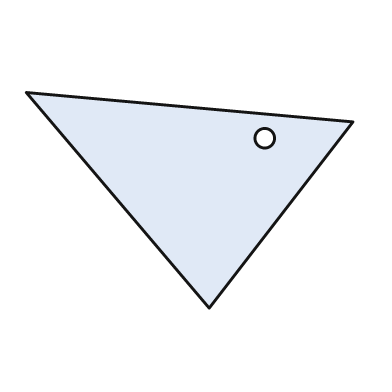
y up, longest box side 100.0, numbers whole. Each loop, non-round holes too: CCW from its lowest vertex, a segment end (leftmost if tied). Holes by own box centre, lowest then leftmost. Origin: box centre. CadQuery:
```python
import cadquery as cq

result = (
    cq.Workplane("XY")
    .moveTo(6.0, -33.0)
    .lineTo(50.0, 24.0)
    .lineTo(-50.0, 33.0)
    .close()
    .moveTo(23.0, 19.0)
    .circle(3.0)
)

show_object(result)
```